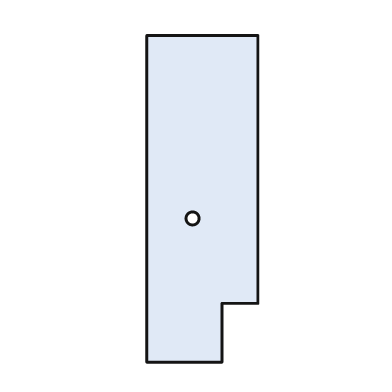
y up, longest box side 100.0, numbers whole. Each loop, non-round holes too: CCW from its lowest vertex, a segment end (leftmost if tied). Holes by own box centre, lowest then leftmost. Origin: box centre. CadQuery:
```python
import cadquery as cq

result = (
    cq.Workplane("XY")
    .moveTo(-17.0, -50.0)
    .lineTo(6.0, -50.0)
    .lineTo(6.0, -32.0)
    .lineTo(17.0, -32.0)
    .lineTo(17.0, 50.0)
    .lineTo(-17.0, 50.0)
    .close()
    .moveTo(-3.0, -6.0)
    .circle(2.0)
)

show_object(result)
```